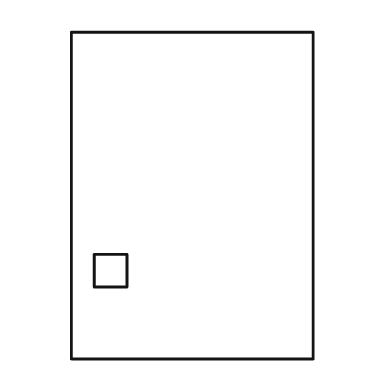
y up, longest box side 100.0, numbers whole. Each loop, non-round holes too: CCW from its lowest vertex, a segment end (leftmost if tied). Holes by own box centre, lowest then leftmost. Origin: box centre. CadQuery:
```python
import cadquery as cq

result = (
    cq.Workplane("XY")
    .moveTo(-37.0, -50.0)
    .lineTo(37.0, -50.0)
    .lineTo(37.0, 50.0)
    .lineTo(-37.0, 50.0)
    .close()
    .moveTo(-30.0, -28.0)
    .lineTo(-20.0, -28.0)
    .lineTo(-20.0, -18.0)
    .lineTo(-30.0, -18.0)
    .close()
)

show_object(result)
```